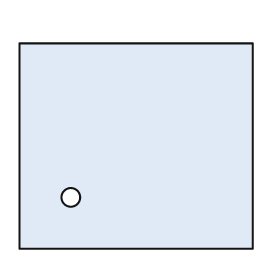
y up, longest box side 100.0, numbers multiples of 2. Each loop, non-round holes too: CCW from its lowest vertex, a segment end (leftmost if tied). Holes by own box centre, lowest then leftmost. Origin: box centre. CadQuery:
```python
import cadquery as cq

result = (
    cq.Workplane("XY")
    .moveTo(-50.0, -44.0)
    .lineTo(50.0, -44.0)
    .lineTo(50.0, 44.0)
    .lineTo(-50.0, 44.0)
    .close()
    .moveTo(-28.0, -22.0)
    .circle(4.0)
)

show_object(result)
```